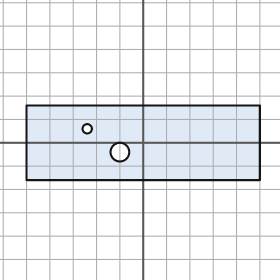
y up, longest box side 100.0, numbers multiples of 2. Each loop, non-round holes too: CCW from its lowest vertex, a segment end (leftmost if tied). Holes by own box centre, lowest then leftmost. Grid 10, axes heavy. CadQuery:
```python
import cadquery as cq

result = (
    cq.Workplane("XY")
    .moveTo(-50.0, -16.0)
    .lineTo(50.0, -16.0)
    .lineTo(50.0, 16.0)
    .lineTo(-50.0, 16.0)
    .close()
    .moveTo(-10.0, -4.0)
    .circle(4.0)
    .moveTo(-24.0, 6.0)
    .circle(2.0)
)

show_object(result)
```